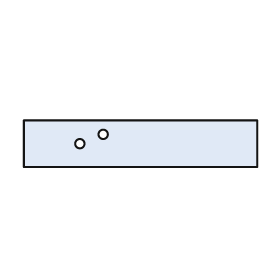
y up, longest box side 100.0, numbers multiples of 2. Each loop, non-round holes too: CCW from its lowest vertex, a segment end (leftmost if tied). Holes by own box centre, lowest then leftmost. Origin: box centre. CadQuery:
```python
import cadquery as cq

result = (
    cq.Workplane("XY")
    .moveTo(-50.0, -10.0)
    .lineTo(50.0, -10.0)
    .lineTo(50.0, 10.0)
    .lineTo(-50.0, 10.0)
    .close()
    .moveTo(-26.0, 0.0)
    .circle(2.0)
    .moveTo(-16.0, 4.0)
    .circle(2.0)
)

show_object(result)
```